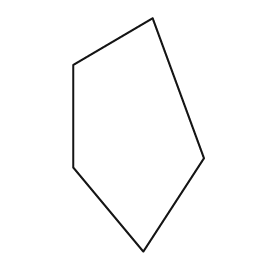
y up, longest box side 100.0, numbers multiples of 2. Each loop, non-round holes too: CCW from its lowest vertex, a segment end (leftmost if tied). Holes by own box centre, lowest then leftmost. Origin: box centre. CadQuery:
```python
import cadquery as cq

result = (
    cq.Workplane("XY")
    .moveTo(2.0, -50.0)
    .lineTo(28.0, -10.0)
    .lineTo(6.0, 50.0)
    .lineTo(-28.0, 30.0)
    .lineTo(-28.0, -14.0)
    .close()
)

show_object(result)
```